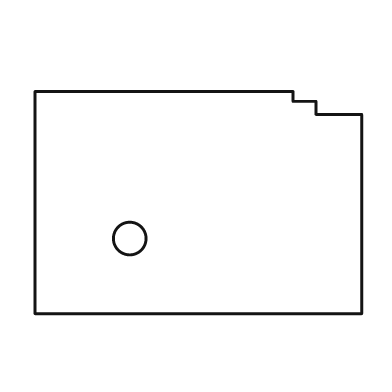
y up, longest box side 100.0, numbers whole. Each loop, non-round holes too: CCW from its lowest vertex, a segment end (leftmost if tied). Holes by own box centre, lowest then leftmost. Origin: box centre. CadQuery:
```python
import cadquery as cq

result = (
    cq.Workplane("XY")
    .moveTo(-50.0, -34.0)
    .lineTo(50.0, -34.0)
    .lineTo(50.0, 27.0)
    .lineTo(36.0, 27.0)
    .lineTo(36.0, 31.0)
    .lineTo(29.0, 31.0)
    .lineTo(29.0, 34.0)
    .lineTo(-50.0, 34.0)
    .close()
    .moveTo(-21.0, -11.0)
    .circle(5.0)
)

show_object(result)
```